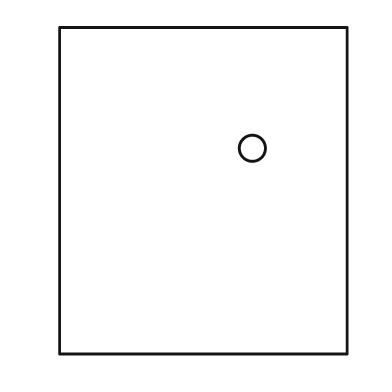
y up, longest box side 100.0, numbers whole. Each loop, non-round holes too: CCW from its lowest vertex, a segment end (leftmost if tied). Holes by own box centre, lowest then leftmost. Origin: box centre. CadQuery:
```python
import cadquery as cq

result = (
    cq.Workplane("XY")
    .moveTo(-44.0, -50.0)
    .lineTo(44.0, -50.0)
    .lineTo(44.0, 50.0)
    .lineTo(-44.0, 50.0)
    .close()
    .moveTo(15.0, 13.0)
    .circle(4.0)
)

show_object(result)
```